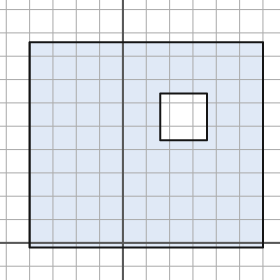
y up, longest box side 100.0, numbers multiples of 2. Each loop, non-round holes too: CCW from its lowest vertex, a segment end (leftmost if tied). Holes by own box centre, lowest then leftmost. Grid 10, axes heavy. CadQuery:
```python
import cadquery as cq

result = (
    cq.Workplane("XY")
    .moveTo(-40.0, -2.0)
    .lineTo(60.0, -2.0)
    .lineTo(60.0, 86.0)
    .lineTo(-40.0, 86.0)
    .close()
    .moveTo(16.0, 44.0)
    .lineTo(36.0, 44.0)
    .lineTo(36.0, 64.0)
    .lineTo(16.0, 64.0)
    .close()
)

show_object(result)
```